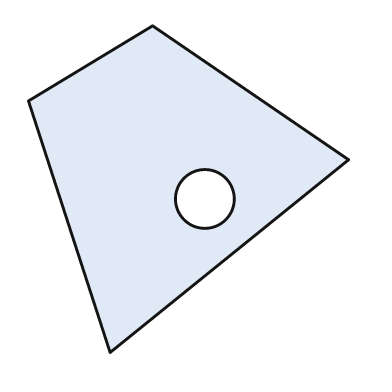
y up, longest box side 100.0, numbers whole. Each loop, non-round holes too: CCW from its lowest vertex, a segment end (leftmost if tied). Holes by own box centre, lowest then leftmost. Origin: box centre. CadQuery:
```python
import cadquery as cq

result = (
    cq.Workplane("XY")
    .moveTo(-24.0, -50.0)
    .lineTo(49.0, 9.0)
    .lineTo(-11.0, 50.0)
    .lineTo(-49.0, 27.0)
    .close()
    .moveTo(5.0, -3.0)
    .circle(9.0)
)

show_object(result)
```